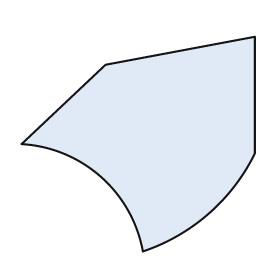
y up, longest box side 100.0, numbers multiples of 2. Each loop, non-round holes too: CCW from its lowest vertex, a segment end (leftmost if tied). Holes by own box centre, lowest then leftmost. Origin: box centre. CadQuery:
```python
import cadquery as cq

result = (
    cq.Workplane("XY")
    .moveTo(2.0, -46.0)
    .threePointArc((30.0, -30.0), (50.0, -4.0))
    .lineTo(50.0, 46.0)
    .lineTo(-14.0, 34.0)
    .lineTo(-50.0, 0.0)
    .threePointArc((-16.0, -14.0), (2.0, -46.0))
    .close()
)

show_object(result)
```